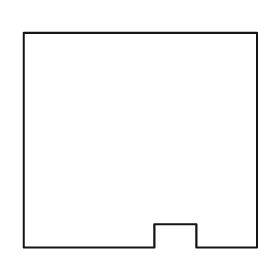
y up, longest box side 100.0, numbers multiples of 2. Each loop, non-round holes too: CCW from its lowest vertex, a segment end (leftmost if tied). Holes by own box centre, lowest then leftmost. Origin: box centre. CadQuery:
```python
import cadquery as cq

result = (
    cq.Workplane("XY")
    .moveTo(-50.0, -46.0)
    .lineTo(6.0, -46.0)
    .lineTo(6.0, -36.0)
    .lineTo(24.0, -36.0)
    .lineTo(24.0, -46.0)
    .lineTo(50.0, -46.0)
    .lineTo(50.0, 46.0)
    .lineTo(-50.0, 46.0)
    .close()
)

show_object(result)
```